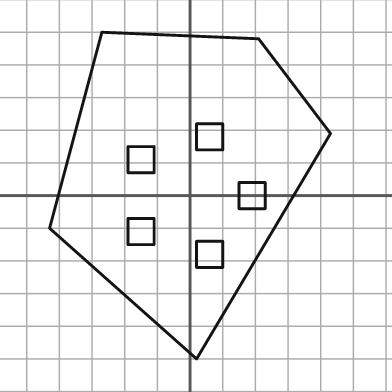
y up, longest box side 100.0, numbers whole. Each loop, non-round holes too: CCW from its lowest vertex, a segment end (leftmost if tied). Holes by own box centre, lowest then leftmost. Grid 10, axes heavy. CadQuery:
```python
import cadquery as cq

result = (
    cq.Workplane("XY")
    .moveTo(2.0, -50.0)
    .lineTo(43.0, 19.0)
    .lineTo(21.0, 48.0)
    .lineTo(-27.0, 50.0)
    .lineTo(-43.0, -10.0)
    .close()
    .moveTo(2.0, -22.0)
    .lineTo(10.0, -22.0)
    .lineTo(10.0, -14.0)
    .lineTo(2.0, -14.0)
    .close()
    .moveTo(-19.0, -15.0)
    .lineTo(-11.0, -15.0)
    .lineTo(-11.0, -7.0)
    .lineTo(-19.0, -7.0)
    .close()
    .moveTo(15.0, -4.0)
    .lineTo(23.0, -4.0)
    .lineTo(23.0, 4.0)
    .lineTo(15.0, 4.0)
    .close()
    .moveTo(-19.0, 7.0)
    .lineTo(-11.0, 7.0)
    .lineTo(-11.0, 15.0)
    .lineTo(-19.0, 15.0)
    .close()
    .moveTo(2.0, 14.0)
    .lineTo(10.0, 14.0)
    .lineTo(10.0, 22.0)
    .lineTo(2.0, 22.0)
    .close()
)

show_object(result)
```